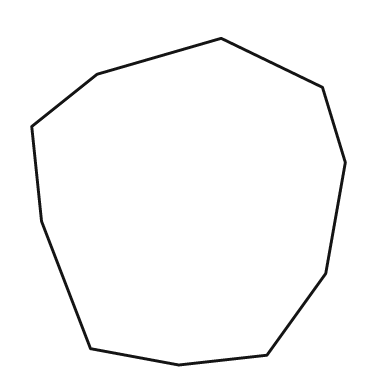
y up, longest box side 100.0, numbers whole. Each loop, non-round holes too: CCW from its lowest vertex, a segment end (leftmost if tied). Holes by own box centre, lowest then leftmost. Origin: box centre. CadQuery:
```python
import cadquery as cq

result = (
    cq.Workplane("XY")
    .moveTo(-3.0, -50.0)
    .lineTo(24.0, -47.0)
    .lineTo(42.0, -22.0)
    .lineTo(48.0, 12.0)
    .lineTo(41.0, 35.0)
    .lineTo(10.0, 50.0)
    .lineTo(-28.0, 39.0)
    .lineTo(-48.0, 23.0)
    .lineTo(-45.0, -6.0)
    .lineTo(-30.0, -45.0)
    .close()
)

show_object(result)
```